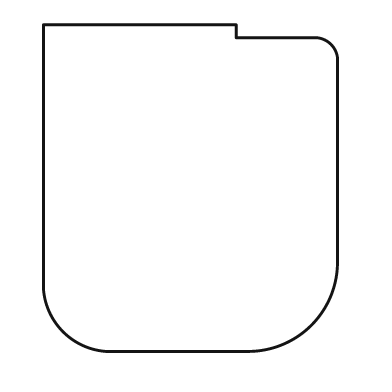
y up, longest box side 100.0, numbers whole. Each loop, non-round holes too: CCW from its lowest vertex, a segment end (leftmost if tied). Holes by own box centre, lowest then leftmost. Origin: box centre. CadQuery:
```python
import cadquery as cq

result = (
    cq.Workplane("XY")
    .moveTo(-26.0, -50.0)
    .lineTo(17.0, -50.0)
    .threePointArc((37.0, -42.0), (45.0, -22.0))
    .lineTo(45.0, 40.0)
    .threePointArc((43.0, 44.0), (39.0, 46.0))
    .lineTo(14.0, 46.0)
    .lineTo(14.0, 50.0)
    .lineTo(-45.0, 50.0)
    .lineTo(-45.0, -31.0)
    .threePointArc((-39.0, -44.0), (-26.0, -50.0))
    .close()
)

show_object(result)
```